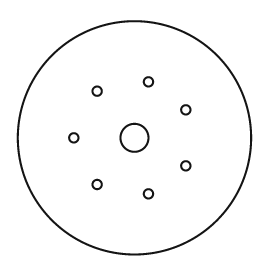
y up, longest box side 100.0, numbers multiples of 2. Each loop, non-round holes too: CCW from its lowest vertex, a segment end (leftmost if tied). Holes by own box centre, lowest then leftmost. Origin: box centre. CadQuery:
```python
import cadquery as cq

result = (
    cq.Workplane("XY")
    .moveTo(0.0, 0.0)
    .circle(50.0)
    .moveTo(6.0, -24.0)
    .circle(2.0)
    .moveTo(-16.0, -20.0)
    .circle(2.0)
    .moveTo(22.0, -12.0)
    .circle(2.0)
    .moveTo(-26.0, 0.0)
    .circle(2.0)
    .moveTo(0.0, 0.0)
    .circle(6.0)
    .moveTo(22.0, 12.0)
    .circle(2.0)
    .moveTo(-16.0, 20.0)
    .circle(2.0)
    .moveTo(6.0, 24.0)
    .circle(2.0)
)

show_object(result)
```